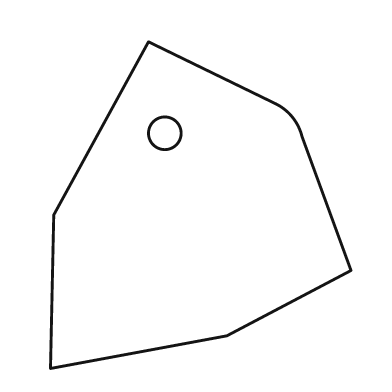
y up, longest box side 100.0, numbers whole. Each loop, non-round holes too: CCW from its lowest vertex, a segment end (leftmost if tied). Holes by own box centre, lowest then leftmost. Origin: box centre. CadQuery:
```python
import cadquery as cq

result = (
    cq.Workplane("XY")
    .moveTo(-46.0, -50.0)
    .lineTo(8.0, -40.0)
    .lineTo(46.0, -20.0)
    .lineTo(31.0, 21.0)
    .threePointArc((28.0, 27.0), (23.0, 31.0))
    .lineTo(-16.0, 50.0)
    .lineTo(-45.0, -3.0)
    .close()
    .moveTo(-11.0, 22.0)
    .circle(5.0)
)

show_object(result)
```